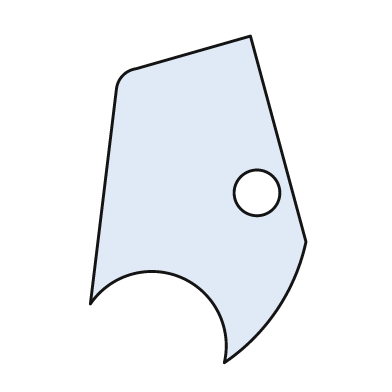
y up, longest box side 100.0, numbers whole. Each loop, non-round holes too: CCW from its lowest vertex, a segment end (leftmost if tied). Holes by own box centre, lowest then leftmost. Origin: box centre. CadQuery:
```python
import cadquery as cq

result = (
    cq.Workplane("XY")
    .moveTo(8.0, -50.0)
    .threePointArc((24.0, -34.0), (33.0, -13.0))
    .lineTo(16.0, 50.0)
    .lineTo(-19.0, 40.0)
    .threePointArc((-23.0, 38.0), (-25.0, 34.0))
    .lineTo(-33.0, -32.0)
    .threePointArc((-5.0, -24.0), (8.0, -50.0))
    .close()
    .moveTo(18.0, 2.0)
    .circle(7.0)
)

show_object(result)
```